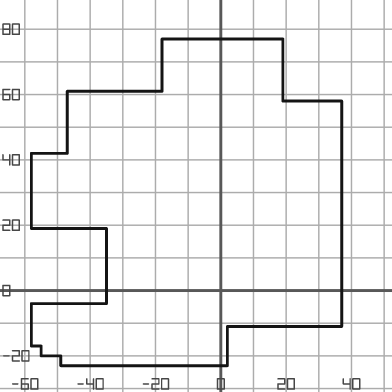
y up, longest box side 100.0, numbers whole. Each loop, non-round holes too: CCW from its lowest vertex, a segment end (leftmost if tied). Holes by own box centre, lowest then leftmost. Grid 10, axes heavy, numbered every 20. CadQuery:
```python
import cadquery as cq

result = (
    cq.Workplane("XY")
    .moveTo(-49.0, -23.0)
    .lineTo(2.0, -23.0)
    .lineTo(2.0, -11.0)
    .lineTo(37.0, -11.0)
    .lineTo(37.0, 58.0)
    .lineTo(19.0, 58.0)
    .lineTo(19.0, 77.0)
    .lineTo(-18.0, 77.0)
    .lineTo(-18.0, 61.0)
    .lineTo(-47.0, 61.0)
    .lineTo(-47.0, 42.0)
    .lineTo(-58.0, 42.0)
    .lineTo(-58.0, 19.0)
    .lineTo(-35.0, 19.0)
    .lineTo(-35.0, -4.0)
    .lineTo(-58.0, -4.0)
    .lineTo(-58.0, -17.0)
    .lineTo(-55.0, -17.0)
    .lineTo(-55.0, -20.0)
    .lineTo(-49.0, -20.0)
    .close()
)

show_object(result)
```